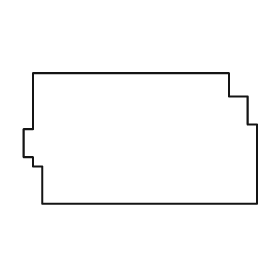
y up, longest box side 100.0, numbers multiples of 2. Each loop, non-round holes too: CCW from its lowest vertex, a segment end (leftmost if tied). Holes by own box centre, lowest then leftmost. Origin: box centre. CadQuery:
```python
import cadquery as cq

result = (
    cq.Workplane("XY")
    .moveTo(-42.0, -28.0)
    .lineTo(50.0, -28.0)
    .lineTo(50.0, 6.0)
    .lineTo(46.0, 6.0)
    .lineTo(46.0, 18.0)
    .lineTo(38.0, 18.0)
    .lineTo(38.0, 28.0)
    .lineTo(-46.0, 28.0)
    .lineTo(-46.0, 4.0)
    .lineTo(-50.0, 4.0)
    .lineTo(-50.0, -8.0)
    .lineTo(-46.0, -8.0)
    .lineTo(-46.0, -12.0)
    .lineTo(-42.0, -12.0)
    .close()
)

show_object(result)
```